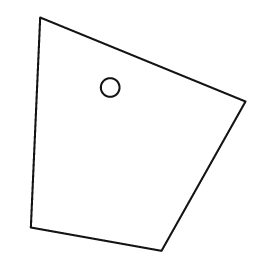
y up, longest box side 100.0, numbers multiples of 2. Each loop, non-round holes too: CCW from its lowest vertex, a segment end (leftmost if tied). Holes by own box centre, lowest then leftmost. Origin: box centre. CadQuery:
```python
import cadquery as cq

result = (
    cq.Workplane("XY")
    .moveTo(10.0, -50.0)
    .lineTo(46.0, 14.0)
    .lineTo(-42.0, 50.0)
    .lineTo(-46.0, -40.0)
    .close()
    .moveTo(-12.0, 20.0)
    .circle(4.0)
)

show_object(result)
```